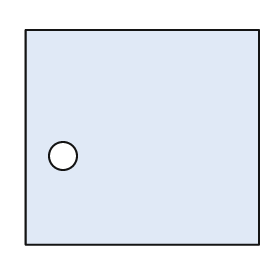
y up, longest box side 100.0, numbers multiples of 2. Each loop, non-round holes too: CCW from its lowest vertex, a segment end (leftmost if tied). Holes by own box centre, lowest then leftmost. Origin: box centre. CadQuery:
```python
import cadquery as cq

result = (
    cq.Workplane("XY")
    .moveTo(-50.0, -46.0)
    .lineTo(50.0, -46.0)
    .lineTo(50.0, 46.0)
    .lineTo(-50.0, 46.0)
    .close()
    .moveTo(-34.0, -8.0)
    .circle(6.0)
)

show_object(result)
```